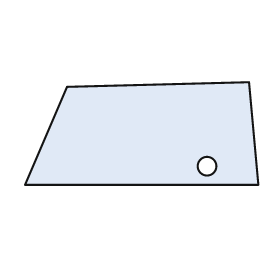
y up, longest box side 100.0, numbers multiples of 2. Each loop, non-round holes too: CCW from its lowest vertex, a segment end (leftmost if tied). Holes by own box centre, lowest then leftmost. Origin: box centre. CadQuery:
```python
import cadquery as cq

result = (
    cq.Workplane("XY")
    .moveTo(-50.0, -22.0)
    .lineTo(50.0, -22.0)
    .lineTo(46.0, 22.0)
    .lineTo(-32.0, 20.0)
    .close()
    .moveTo(28.0, -14.0)
    .circle(4.0)
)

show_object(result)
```